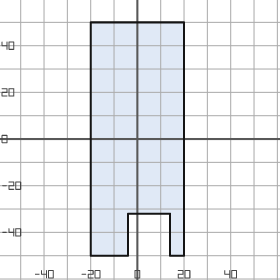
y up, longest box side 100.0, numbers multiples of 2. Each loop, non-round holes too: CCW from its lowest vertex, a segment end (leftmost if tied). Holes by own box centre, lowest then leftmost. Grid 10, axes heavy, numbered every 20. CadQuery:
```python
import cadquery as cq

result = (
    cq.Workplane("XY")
    .moveTo(-20.0, -50.0)
    .lineTo(-4.0, -50.0)
    .lineTo(-4.0, -32.0)
    .lineTo(14.0, -32.0)
    .lineTo(14.0, -50.0)
    .lineTo(20.0, -50.0)
    .lineTo(20.0, 50.0)
    .lineTo(-20.0, 50.0)
    .close()
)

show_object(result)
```